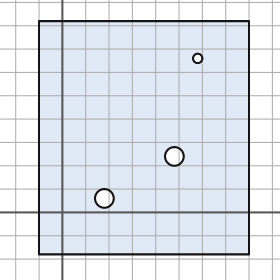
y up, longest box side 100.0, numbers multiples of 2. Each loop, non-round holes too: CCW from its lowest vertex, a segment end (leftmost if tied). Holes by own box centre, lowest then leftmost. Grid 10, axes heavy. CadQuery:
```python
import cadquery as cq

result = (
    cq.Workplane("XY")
    .moveTo(-10.0, -18.0)
    .lineTo(80.0, -18.0)
    .lineTo(80.0, 82.0)
    .lineTo(-10.0, 82.0)
    .close()
    .moveTo(18.0, 6.0)
    .circle(4.0)
    .moveTo(48.0, 24.0)
    .circle(4.0)
    .moveTo(58.0, 66.0)
    .circle(2.0)
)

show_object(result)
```